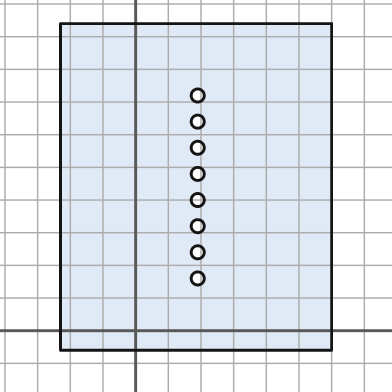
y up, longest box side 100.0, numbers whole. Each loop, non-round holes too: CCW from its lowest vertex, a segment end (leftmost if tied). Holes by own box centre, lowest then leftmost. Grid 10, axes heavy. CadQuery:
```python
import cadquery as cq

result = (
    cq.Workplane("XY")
    .moveTo(-23.0, -6.0)
    .lineTo(60.0, -6.0)
    .lineTo(60.0, 94.0)
    .lineTo(-23.0, 94.0)
    .close()
    .moveTo(19.0, 16.0)
    .circle(2.0)
    .moveTo(19.0, 24.0)
    .circle(2.0)
    .moveTo(19.0, 32.0)
    .circle(2.0)
    .moveTo(19.0, 40.0)
    .circle(2.0)
    .moveTo(19.0, 48.0)
    .circle(2.0)
    .moveTo(19.0, 56.0)
    .circle(2.0)
    .moveTo(19.0, 64.0)
    .circle(2.0)
    .moveTo(19.0, 72.0)
    .circle(2.0)
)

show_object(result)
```